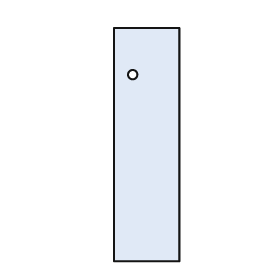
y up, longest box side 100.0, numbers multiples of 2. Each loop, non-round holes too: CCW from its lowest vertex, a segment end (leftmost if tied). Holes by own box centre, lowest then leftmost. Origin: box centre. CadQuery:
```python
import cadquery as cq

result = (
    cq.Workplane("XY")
    .moveTo(-14.0, -50.0)
    .lineTo(14.0, -50.0)
    .lineTo(14.0, 50.0)
    .lineTo(-14.0, 50.0)
    .close()
    .moveTo(-6.0, 30.0)
    .circle(2.0)
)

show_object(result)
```